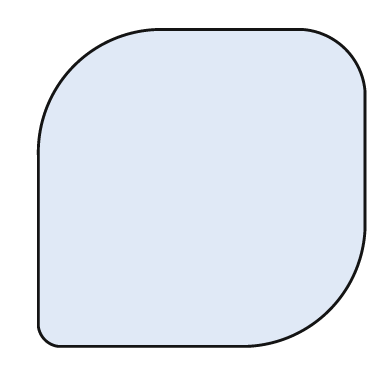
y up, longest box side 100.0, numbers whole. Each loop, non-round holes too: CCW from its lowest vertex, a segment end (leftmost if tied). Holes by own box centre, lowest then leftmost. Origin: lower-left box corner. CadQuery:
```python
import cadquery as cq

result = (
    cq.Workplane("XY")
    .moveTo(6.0, 0.0)
    .lineTo(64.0, 0.0)
    .threePointArc((89.0, 11.0), (100.0, 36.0))
    .lineTo(100.0, 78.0)
    .threePointArc((94.0, 91.0), (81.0, 97.0))
    .lineTo(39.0, 97.0)
    .threePointArc((11.0, 86.0), (0.0, 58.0))
    .lineTo(0.0, 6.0)
    .threePointArc((2.0, 2.0), (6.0, 0.0))
    .close()
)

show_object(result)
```